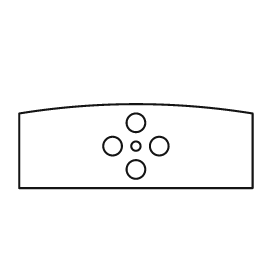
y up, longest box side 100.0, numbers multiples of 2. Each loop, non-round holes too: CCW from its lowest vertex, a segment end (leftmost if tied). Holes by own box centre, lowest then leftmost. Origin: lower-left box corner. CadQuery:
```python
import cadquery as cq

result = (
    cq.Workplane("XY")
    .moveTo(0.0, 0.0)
    .lineTo(100.0, 0.0)
    .lineTo(100.0, 32.0)
    .threePointArc((50.0, 36.0), (0.0, 32.0))
    .close()
    .moveTo(50.0, 8.0)
    .circle(4.0)
    .moveTo(40.0, 18.0)
    .circle(4.0)
    .moveTo(50.0, 18.0)
    .circle(2.0)
    .moveTo(60.0, 18.0)
    .circle(4.0)
    .moveTo(50.0, 28.0)
    .circle(4.0)
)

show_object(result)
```